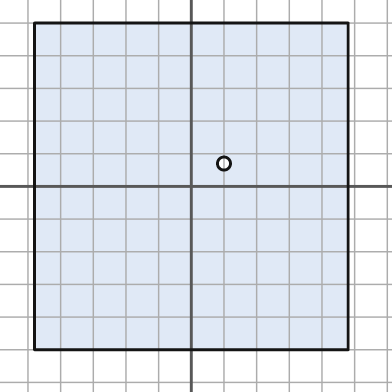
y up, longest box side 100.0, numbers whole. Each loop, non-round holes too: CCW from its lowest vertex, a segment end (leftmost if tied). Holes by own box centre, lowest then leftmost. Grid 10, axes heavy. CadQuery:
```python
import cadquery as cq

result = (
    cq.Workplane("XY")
    .moveTo(-48.0, -50.0)
    .lineTo(48.0, -50.0)
    .lineTo(48.0, 50.0)
    .lineTo(-48.0, 50.0)
    .close()
    .moveTo(10.0, 7.0)
    .circle(2.0)
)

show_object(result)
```